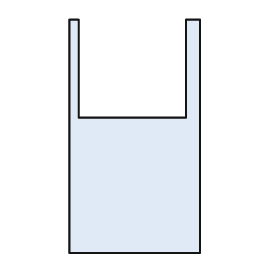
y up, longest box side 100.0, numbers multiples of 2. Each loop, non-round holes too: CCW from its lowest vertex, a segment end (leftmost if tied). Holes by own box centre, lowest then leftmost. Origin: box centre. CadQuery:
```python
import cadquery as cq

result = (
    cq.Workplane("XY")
    .moveTo(-28.0, -50.0)
    .lineTo(28.0, -50.0)
    .lineTo(28.0, 50.0)
    .lineTo(22.0, 50.0)
    .lineTo(22.0, 8.0)
    .lineTo(-24.0, 8.0)
    .lineTo(-24.0, 50.0)
    .lineTo(-28.0, 50.0)
    .close()
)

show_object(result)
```